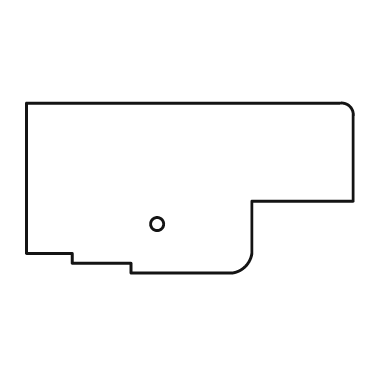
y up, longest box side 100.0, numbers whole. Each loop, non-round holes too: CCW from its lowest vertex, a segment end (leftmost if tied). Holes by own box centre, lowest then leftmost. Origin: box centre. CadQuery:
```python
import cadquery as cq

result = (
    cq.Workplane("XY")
    .moveTo(-18.0, -26.0)
    .lineTo(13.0, -26.0)
    .threePointArc((17.0, -24.0), (19.0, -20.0))
    .lineTo(19.0, -4.0)
    .lineTo(50.0, -4.0)
    .lineTo(50.0, 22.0)
    .threePointArc((49.0, 25.0), (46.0, 26.0))
    .lineTo(-50.0, 26.0)
    .lineTo(-50.0, -20.0)
    .lineTo(-36.0, -20.0)
    .lineTo(-36.0, -23.0)
    .lineTo(-18.0, -23.0)
    .close()
    .moveTo(-10.0, -11.0)
    .circle(2.0)
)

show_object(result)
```